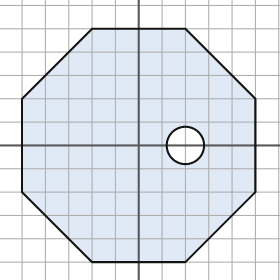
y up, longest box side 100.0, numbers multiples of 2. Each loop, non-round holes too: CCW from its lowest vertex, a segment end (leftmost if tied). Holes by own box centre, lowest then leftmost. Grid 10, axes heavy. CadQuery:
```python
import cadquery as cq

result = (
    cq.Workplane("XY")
    .moveTo(-20.0, -50.0)
    .lineTo(20.0, -50.0)
    .lineTo(50.0, -20.0)
    .lineTo(50.0, 20.0)
    .lineTo(20.0, 50.0)
    .lineTo(-20.0, 50.0)
    .lineTo(-50.0, 20.0)
    .lineTo(-50.0, -20.0)
    .close()
    .moveTo(20.0, 0.0)
    .circle(8.0)
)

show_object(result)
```